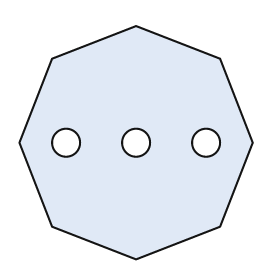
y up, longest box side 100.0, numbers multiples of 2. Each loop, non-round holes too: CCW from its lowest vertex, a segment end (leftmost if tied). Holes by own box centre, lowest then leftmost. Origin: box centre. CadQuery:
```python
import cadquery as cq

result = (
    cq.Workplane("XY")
    .moveTo(0.0, -50.0)
    .lineTo(36.0, -36.0)
    .lineTo(50.0, 0.0)
    .lineTo(36.0, 36.0)
    .lineTo(0.0, 50.0)
    .lineTo(-36.0, 36.0)
    .lineTo(-50.0, 0.0)
    .lineTo(-36.0, -36.0)
    .close()
    .moveTo(-30.0, 0.0)
    .circle(6.0)
    .moveTo(0.0, 0.0)
    .circle(6.0)
    .moveTo(30.0, 0.0)
    .circle(6.0)
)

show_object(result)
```